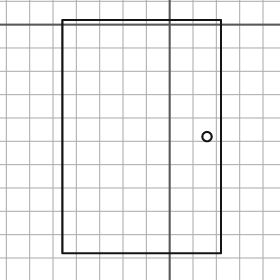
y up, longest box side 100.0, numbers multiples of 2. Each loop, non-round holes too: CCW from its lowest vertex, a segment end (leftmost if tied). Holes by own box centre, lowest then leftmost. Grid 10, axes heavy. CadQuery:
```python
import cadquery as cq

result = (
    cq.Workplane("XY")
    .moveTo(-46.0, -98.0)
    .lineTo(22.0, -98.0)
    .lineTo(22.0, 2.0)
    .lineTo(-46.0, 2.0)
    .close()
    .moveTo(16.0, -48.0)
    .circle(2.0)
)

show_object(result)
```